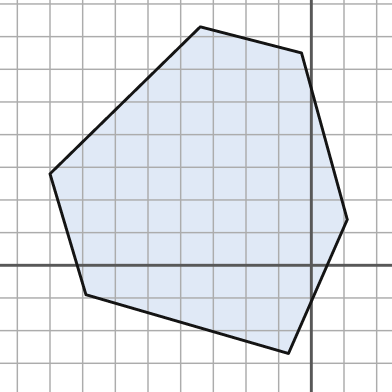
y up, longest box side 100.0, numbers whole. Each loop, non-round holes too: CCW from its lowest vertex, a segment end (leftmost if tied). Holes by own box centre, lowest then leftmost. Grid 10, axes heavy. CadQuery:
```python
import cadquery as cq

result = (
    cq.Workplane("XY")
    .moveTo(-7.0, -27.0)
    .lineTo(11.0, 14.0)
    .lineTo(-3.0, 65.0)
    .lineTo(-34.0, 73.0)
    .lineTo(-80.0, 28.0)
    .lineTo(-69.0, -9.0)
    .close()
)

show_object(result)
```